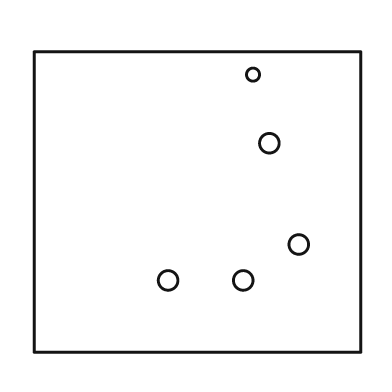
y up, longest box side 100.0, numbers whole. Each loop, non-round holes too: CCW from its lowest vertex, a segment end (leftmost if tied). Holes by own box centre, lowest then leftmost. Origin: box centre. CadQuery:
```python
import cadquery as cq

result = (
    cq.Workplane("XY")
    .moveTo(-50.0, -46.0)
    .lineTo(50.0, -46.0)
    .lineTo(50.0, 46.0)
    .lineTo(-50.0, 46.0)
    .close()
    .moveTo(-9.0, -24.0)
    .circle(3.0)
    .moveTo(14.0, -24.0)
    .circle(3.0)
    .moveTo(31.0, -13.0)
    .circle(3.0)
    .moveTo(22.0, 18.0)
    .circle(3.0)
    .moveTo(17.0, 39.0)
    .circle(2.0)
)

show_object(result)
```